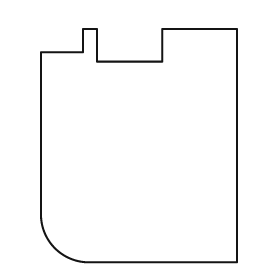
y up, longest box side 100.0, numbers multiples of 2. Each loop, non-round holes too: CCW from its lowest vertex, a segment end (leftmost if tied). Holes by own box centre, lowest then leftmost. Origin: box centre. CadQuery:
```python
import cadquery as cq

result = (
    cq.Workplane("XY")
    .moveTo(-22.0, -50.0)
    .lineTo(42.0, -50.0)
    .lineTo(42.0, 50.0)
    .lineTo(10.0, 50.0)
    .lineTo(10.0, 36.0)
    .lineTo(-18.0, 36.0)
    .lineTo(-18.0, 50.0)
    .lineTo(-24.0, 50.0)
    .lineTo(-24.0, 40.0)
    .lineTo(-42.0, 40.0)
    .lineTo(-42.0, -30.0)
    .threePointArc((-36.0, -44.0), (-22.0, -50.0))
    .close()
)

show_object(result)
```